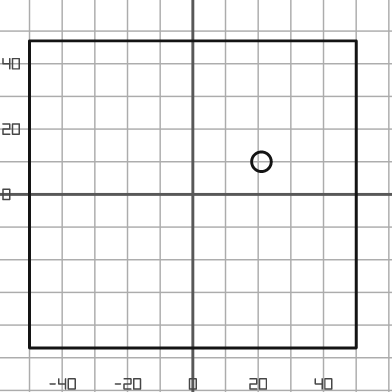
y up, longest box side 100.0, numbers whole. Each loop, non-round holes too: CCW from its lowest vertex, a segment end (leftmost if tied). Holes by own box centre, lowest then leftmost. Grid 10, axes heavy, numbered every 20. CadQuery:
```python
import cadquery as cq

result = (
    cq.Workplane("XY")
    .moveTo(-50.0, -47.0)
    .lineTo(50.0, -47.0)
    .lineTo(50.0, 47.0)
    .lineTo(-50.0, 47.0)
    .close()
    .moveTo(21.0, 10.0)
    .circle(3.0)
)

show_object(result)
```